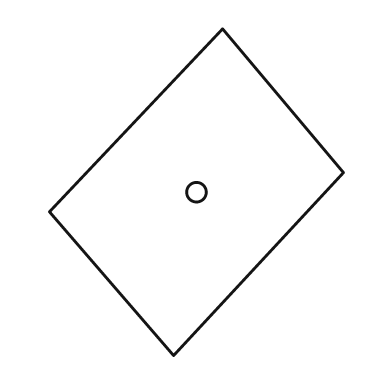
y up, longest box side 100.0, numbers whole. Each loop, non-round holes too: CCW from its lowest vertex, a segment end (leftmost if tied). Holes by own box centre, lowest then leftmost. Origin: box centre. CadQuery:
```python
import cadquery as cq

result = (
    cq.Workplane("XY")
    .moveTo(-7.0, -50.0)
    .lineTo(45.0, 6.0)
    .lineTo(8.0, 50.0)
    .lineTo(-45.0, -6.0)
    .close()
    .moveTo(0.0, 0.0)
    .circle(3.0)
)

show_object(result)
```